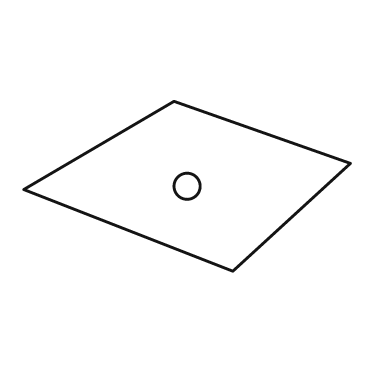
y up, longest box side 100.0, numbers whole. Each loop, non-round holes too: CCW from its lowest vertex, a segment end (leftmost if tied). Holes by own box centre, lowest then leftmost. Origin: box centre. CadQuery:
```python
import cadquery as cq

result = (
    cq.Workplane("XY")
    .moveTo(14.0, -26.0)
    .lineTo(50.0, 7.0)
    .lineTo(-4.0, 26.0)
    .lineTo(-50.0, -1.0)
    .close()
    .moveTo(0.0, 0.0)
    .circle(4.0)
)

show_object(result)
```